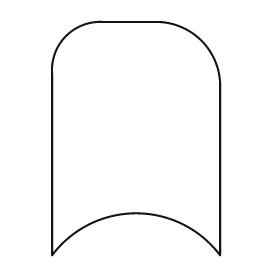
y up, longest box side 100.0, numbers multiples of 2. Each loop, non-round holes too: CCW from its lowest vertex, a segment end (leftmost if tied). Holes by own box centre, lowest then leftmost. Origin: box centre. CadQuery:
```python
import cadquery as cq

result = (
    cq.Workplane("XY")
    .moveTo(-36.0, -50.0)
    .threePointArc((0.0, -32.0), (36.0, -50.0))
    .lineTo(36.0, 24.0)
    .threePointArc((28.0, 42.0), (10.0, 50.0))
    .lineTo(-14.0, 50.0)
    .threePointArc((-30.0, 44.0), (-36.0, 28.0))
    .close()
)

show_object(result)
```